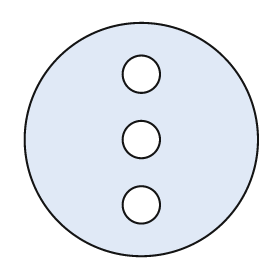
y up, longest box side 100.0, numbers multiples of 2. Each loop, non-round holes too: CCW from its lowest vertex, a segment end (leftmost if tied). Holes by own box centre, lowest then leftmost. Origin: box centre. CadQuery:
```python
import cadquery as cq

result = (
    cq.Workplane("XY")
    .moveTo(0.0, 0.0)
    .circle(50.0)
    .moveTo(0.0, -28.0)
    .circle(8.0)
    .moveTo(0.0, 0.0)
    .circle(8.0)
    .moveTo(0.0, 28.0)
    .circle(8.0)
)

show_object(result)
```